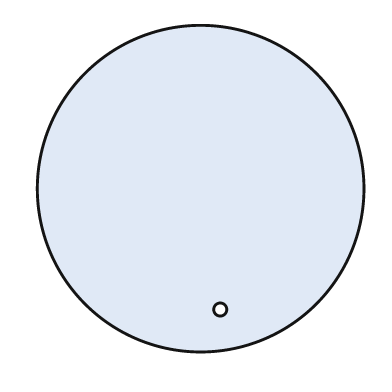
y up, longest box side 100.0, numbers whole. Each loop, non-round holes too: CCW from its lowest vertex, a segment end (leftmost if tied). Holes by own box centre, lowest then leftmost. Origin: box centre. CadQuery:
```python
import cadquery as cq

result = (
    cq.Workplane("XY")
    .moveTo(0.0, 0.0)
    .circle(50.0)
    .moveTo(6.0, -37.0)
    .circle(2.0)
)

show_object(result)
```